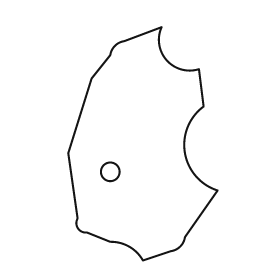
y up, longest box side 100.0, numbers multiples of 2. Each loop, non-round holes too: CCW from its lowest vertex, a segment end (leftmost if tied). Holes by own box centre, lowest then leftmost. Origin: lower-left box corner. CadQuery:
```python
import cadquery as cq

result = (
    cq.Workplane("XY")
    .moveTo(32.0, 0.0)
    .lineTo(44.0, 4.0)
    .threePointArc((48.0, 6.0), (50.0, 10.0))
    .lineTo(64.0, 30.0)
    .threePointArc((50.0, 46.0), (58.0, 66.0))
    .lineTo(56.0, 82.0)
    .threePointArc((42.0, 86.0), (40.0, 100.0))
    .lineTo(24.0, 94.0)
    .threePointArc((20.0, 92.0), (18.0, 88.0))
    .lineTo(10.0, 78.0)
    .lineTo(0.0, 46.0)
    .lineTo(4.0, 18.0)
    .threePointArc((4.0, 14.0), (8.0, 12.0))
    .lineTo(18.0, 8.0)
    .threePointArc((26.0, 6.0), (32.0, 0.0))
    .close()
    .moveTo(18.0, 38.0)
    .circle(4.0)
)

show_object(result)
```